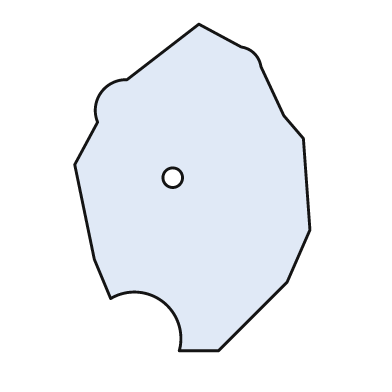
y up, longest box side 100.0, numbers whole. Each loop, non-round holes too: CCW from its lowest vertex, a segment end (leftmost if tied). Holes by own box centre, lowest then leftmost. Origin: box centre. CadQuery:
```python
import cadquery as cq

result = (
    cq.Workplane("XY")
    .moveTo(-4.0, -50.0)
    .lineTo(8.0, -50.0)
    .lineTo(29.0, -29.0)
    .lineTo(36.0, -13.0)
    .lineTo(34.0, 15.0)
    .lineTo(28.0, 22.0)
    .lineTo(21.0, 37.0)
    .threePointArc((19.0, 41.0), (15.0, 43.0))
    .lineTo(2.0, 50.0)
    .lineTo(-20.0, 33.0)
    .threePointArc((-28.0, 29.0), (-29.0, 20.0))
    .lineTo(-36.0, 7.0)
    .lineTo(-30.0, -22.0)
    .lineTo(-25.0, -34.0)
    .threePointArc((-9.0, -35.0), (-4.0, -50.0))
    .close()
    .moveTo(-6.0, 3.0)
    .circle(3.0)
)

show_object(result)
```